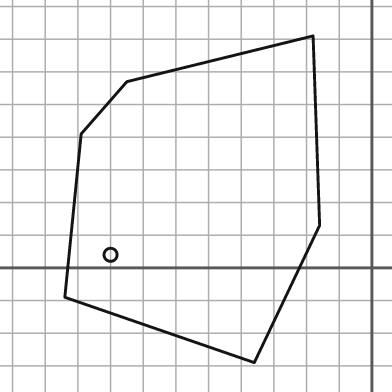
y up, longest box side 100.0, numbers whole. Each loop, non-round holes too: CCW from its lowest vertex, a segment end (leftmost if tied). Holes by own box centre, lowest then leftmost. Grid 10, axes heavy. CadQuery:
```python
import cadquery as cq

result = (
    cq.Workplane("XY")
    .moveTo(-36.0, -29.0)
    .lineTo(-16.0, 13.0)
    .lineTo(-18.0, 71.0)
    .lineTo(-75.0, 57.0)
    .lineTo(-89.0, 41.0)
    .lineTo(-94.0, -9.0)
    .close()
    .moveTo(-80.0, 4.0)
    .circle(2.0)
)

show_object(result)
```